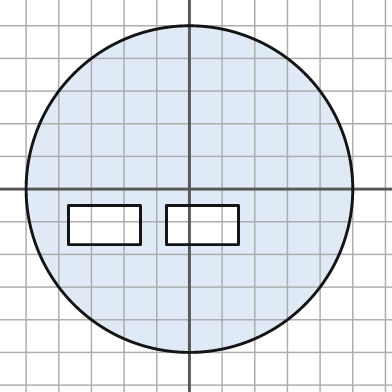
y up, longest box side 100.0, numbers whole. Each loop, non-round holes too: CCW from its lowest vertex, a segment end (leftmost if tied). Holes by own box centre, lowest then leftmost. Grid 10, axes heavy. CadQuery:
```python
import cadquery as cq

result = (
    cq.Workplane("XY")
    .moveTo(0.0, 0.0)
    .circle(50.0)
    .moveTo(-37.0, -17.0)
    .lineTo(-15.0, -17.0)
    .lineTo(-15.0, -5.0)
    .lineTo(-37.0, -5.0)
    .close()
    .moveTo(-7.0, -17.0)
    .lineTo(15.0, -17.0)
    .lineTo(15.0, -5.0)
    .lineTo(-7.0, -5.0)
    .close()
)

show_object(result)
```